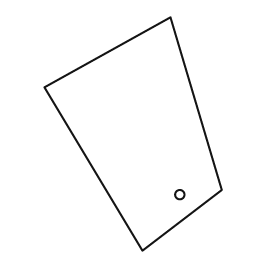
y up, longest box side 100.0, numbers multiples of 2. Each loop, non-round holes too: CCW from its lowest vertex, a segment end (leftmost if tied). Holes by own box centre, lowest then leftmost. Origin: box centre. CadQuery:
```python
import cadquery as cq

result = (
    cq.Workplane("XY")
    .moveTo(4.0, -50.0)
    .lineTo(38.0, -24.0)
    .lineTo(16.0, 50.0)
    .lineTo(-38.0, 20.0)
    .close()
    .moveTo(20.0, -26.0)
    .circle(2.0)
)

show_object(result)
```